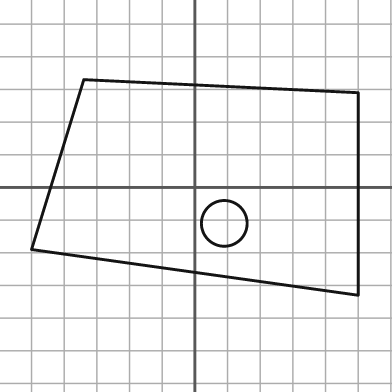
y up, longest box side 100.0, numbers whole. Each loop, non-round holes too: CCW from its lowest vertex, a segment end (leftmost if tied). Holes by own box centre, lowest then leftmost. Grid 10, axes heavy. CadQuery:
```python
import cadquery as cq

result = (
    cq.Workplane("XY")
    .moveTo(50.0, -33.0)
    .lineTo(50.0, 29.0)
    .lineTo(-34.0, 33.0)
    .lineTo(-50.0, -19.0)
    .close()
    .moveTo(9.0, -11.0)
    .circle(7.0)
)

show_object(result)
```